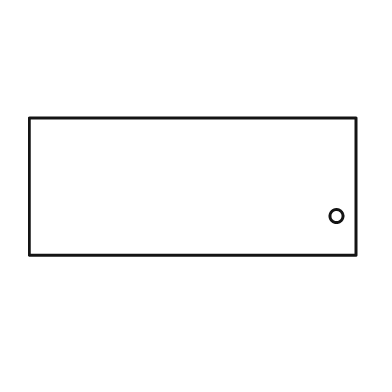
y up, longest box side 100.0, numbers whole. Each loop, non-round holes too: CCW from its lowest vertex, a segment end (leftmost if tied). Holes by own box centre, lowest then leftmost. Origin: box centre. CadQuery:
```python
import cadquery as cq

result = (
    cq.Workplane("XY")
    .moveTo(-50.0, -21.0)
    .lineTo(50.0, -21.0)
    .lineTo(50.0, 21.0)
    .lineTo(-50.0, 21.0)
    .close()
    .moveTo(44.0, -9.0)
    .circle(2.0)
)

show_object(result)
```